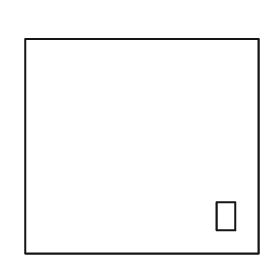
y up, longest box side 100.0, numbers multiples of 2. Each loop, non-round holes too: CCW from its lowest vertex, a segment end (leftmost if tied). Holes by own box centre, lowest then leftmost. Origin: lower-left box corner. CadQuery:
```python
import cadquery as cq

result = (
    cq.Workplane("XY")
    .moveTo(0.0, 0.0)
    .lineTo(100.0, 0.0)
    .lineTo(100.0, 92.0)
    .lineTo(0.0, 92.0)
    .close()
    .moveTo(82.0, 10.0)
    .lineTo(90.0, 10.0)
    .lineTo(90.0, 22.0)
    .lineTo(82.0, 22.0)
    .close()
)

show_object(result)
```